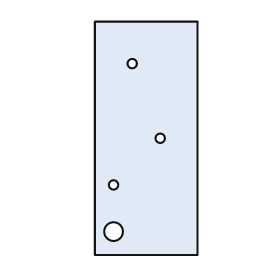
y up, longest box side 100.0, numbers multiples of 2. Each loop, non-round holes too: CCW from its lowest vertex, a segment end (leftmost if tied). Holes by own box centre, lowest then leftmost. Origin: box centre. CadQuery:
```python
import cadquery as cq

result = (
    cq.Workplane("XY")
    .moveTo(-22.0, -50.0)
    .lineTo(22.0, -50.0)
    .lineTo(22.0, 50.0)
    .lineTo(-22.0, 50.0)
    .close()
    .moveTo(-14.0, -40.0)
    .circle(4.0)
    .moveTo(-14.0, -20.0)
    .circle(2.0)
    .moveTo(6.0, 0.0)
    .circle(2.0)
    .moveTo(-6.0, 32.0)
    .circle(2.0)
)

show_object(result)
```